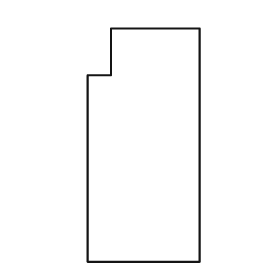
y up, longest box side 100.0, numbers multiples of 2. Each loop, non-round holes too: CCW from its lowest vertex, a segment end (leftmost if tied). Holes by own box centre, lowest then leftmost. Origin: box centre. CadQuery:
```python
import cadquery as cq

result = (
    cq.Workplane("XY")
    .moveTo(-24.0, -50.0)
    .lineTo(24.0, -50.0)
    .lineTo(24.0, 50.0)
    .lineTo(-14.0, 50.0)
    .lineTo(-14.0, 30.0)
    .lineTo(-24.0, 30.0)
    .close()
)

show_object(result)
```